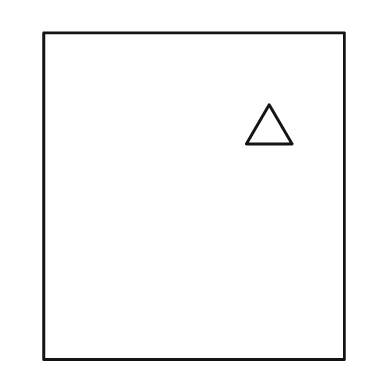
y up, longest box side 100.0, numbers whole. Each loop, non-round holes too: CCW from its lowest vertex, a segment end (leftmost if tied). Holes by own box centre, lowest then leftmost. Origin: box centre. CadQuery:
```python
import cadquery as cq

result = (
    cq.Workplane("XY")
    .moveTo(-46.0, -50.0)
    .lineTo(46.0, -50.0)
    .lineTo(46.0, 50.0)
    .lineTo(-46.0, 50.0)
    .close()
    .moveTo(16.0, 16.0)
    .lineTo(30.0, 16.0)
    .lineTo(23.0, 28.0)
    .close()
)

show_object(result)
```